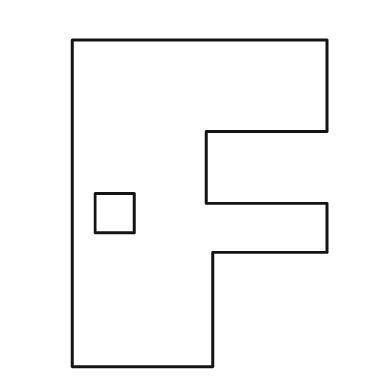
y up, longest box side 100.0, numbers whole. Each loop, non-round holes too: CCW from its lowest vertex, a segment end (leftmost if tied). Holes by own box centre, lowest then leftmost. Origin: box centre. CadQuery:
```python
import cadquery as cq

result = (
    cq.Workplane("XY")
    .moveTo(-39.0, -50.0)
    .lineTo(4.0, -50.0)
    .lineTo(4.0, -15.0)
    .lineTo(39.0, -15.0)
    .lineTo(39.0, 0.0)
    .lineTo(2.0, 0.0)
    .lineTo(2.0, 22.0)
    .lineTo(39.0, 22.0)
    .lineTo(39.0, 50.0)
    .lineTo(-39.0, 50.0)
    .close()
    .moveTo(-32.0, -9.0)
    .lineTo(-20.0, -9.0)
    .lineTo(-20.0, 3.0)
    .lineTo(-32.0, 3.0)
    .close()
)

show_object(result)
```